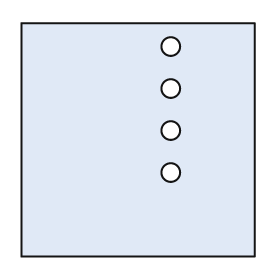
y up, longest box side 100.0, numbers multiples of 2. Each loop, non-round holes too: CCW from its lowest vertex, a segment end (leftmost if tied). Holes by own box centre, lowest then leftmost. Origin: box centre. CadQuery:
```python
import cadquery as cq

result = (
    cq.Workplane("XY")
    .moveTo(-50.0, -50.0)
    .lineTo(50.0, -50.0)
    .lineTo(50.0, 50.0)
    .lineTo(-50.0, 50.0)
    .close()
    .moveTo(14.0, -14.0)
    .circle(4.0)
    .moveTo(14.0, 4.0)
    .circle(4.0)
    .moveTo(14.0, 22.0)
    .circle(4.0)
    .moveTo(14.0, 40.0)
    .circle(4.0)
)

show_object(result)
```